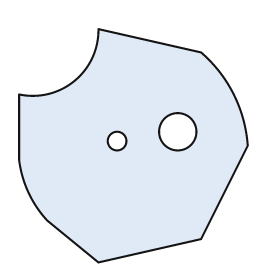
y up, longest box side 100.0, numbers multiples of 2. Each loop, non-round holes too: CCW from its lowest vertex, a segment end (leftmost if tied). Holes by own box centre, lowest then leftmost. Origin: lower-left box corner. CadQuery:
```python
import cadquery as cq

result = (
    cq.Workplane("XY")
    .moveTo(34.0, 0.0)
    .lineTo(78.0, 10.0)
    .lineTo(98.0, 50.0)
    .threePointArc((92.0, 72.0), (78.0, 90.0))
    .lineTo(34.0, 100.0)
    .threePointArc((24.0, 78.0), (0.0, 72.0))
    .lineTo(0.0, 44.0)
    .threePointArc((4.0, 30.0), (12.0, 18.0))
    .close()
    .moveTo(42.0, 52.0)
    .circle(4.0)
    .moveTo(68.0, 56.0)
    .circle(8.0)
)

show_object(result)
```